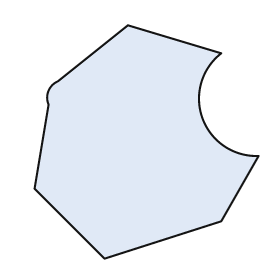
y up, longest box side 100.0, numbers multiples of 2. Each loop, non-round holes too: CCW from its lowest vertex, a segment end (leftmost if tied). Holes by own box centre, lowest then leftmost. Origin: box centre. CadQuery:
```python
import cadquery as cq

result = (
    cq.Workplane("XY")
    .moveTo(-18.0, -50.0)
    .lineTo(32.0, -34.0)
    .lineTo(48.0, -6.0)
    .threePointArc((24.0, 10.0), (32.0, 38.0))
    .lineTo(-8.0, 50.0)
    .lineTo(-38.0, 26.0)
    .threePointArc((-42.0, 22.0), (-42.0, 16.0))
    .lineTo(-48.0, -20.0)
    .close()
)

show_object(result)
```